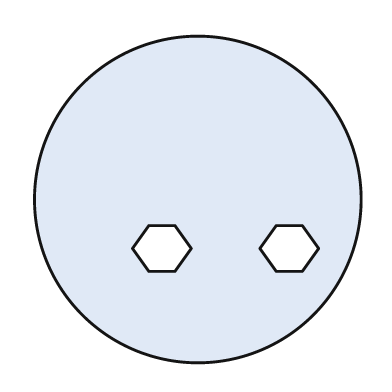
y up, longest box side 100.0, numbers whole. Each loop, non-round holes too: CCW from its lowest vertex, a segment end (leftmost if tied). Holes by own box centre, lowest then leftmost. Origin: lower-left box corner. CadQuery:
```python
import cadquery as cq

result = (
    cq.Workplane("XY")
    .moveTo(50.0, 50.0)
    .circle(50.0)
    .moveTo(35.0, 28.0)
    .lineTo(43.0, 28.0)
    .lineTo(48.0, 35.0)
    .lineTo(43.0, 42.0)
    .lineTo(35.0, 42.0)
    .lineTo(30.0, 35.0)
    .close()
    .moveTo(74.0, 28.0)
    .lineTo(82.0, 28.0)
    .lineTo(87.0, 35.0)
    .lineTo(82.0, 42.0)
    .lineTo(74.0, 42.0)
    .lineTo(69.0, 35.0)
    .close()
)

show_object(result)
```